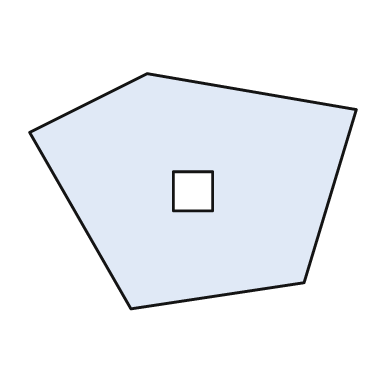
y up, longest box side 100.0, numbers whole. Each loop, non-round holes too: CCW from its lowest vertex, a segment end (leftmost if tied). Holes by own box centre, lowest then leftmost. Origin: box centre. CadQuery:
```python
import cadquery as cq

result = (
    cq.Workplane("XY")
    .moveTo(-19.0, -36.0)
    .lineTo(34.0, -28.0)
    .lineTo(50.0, 25.0)
    .lineTo(-14.0, 36.0)
    .lineTo(-50.0, 18.0)
    .close()
    .moveTo(-6.0, -6.0)
    .lineTo(6.0, -6.0)
    .lineTo(6.0, 6.0)
    .lineTo(-6.0, 6.0)
    .close()
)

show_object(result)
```